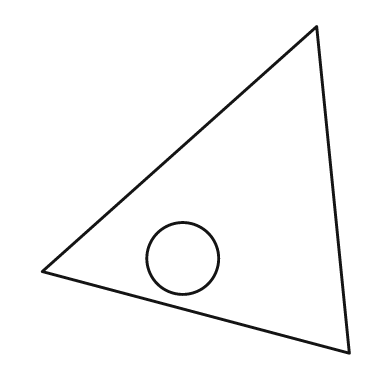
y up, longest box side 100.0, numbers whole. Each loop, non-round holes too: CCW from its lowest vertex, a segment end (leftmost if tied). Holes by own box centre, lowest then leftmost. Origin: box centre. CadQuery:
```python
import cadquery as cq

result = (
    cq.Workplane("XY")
    .moveTo(47.0, -50.0)
    .lineTo(37.0, 50.0)
    .lineTo(-47.0, -25.0)
    .close()
    .moveTo(-4.0, -21.0)
    .circle(11.0)
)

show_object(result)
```